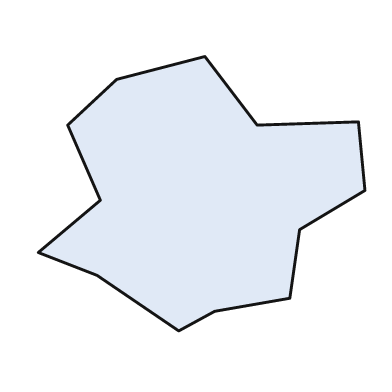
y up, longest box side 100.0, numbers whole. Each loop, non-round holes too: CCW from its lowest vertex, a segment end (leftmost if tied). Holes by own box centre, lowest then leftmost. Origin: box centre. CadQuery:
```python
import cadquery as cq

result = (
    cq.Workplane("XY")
    .moveTo(-7.0, -42.0)
    .lineTo(4.0, -36.0)
    .lineTo(27.0, -32.0)
    .lineTo(30.0, -11.0)
    .lineTo(50.0, 1.0)
    .lineTo(48.0, 22.0)
    .lineTo(17.0, 21.0)
    .lineTo(1.0, 42.0)
    .lineTo(-26.0, 35.0)
    .lineTo(-41.0, 21.0)
    .lineTo(-31.0, -2.0)
    .lineTo(-50.0, -18.0)
    .lineTo(-32.0, -25.0)
    .close()
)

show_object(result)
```